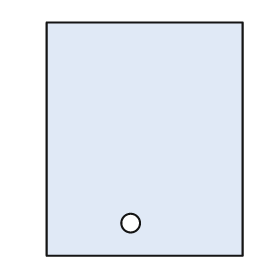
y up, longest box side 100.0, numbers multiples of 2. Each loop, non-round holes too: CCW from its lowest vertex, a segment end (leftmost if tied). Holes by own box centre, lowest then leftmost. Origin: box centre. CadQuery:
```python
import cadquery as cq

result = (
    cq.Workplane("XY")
    .moveTo(-42.0, -50.0)
    .lineTo(42.0, -50.0)
    .lineTo(42.0, 50.0)
    .lineTo(-42.0, 50.0)
    .close()
    .moveTo(-6.0, -36.0)
    .circle(4.0)
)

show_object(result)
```